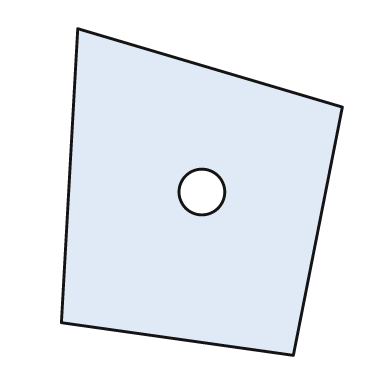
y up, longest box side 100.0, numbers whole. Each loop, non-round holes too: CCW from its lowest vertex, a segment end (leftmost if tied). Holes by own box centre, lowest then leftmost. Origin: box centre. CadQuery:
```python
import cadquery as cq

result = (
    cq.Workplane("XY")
    .moveTo(28.0, -50.0)
    .lineTo(43.0, 26.0)
    .lineTo(-38.0, 50.0)
    .lineTo(-43.0, -40.0)
    .close()
    .moveTo(0.0, 0.0)
    .circle(7.0)
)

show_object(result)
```